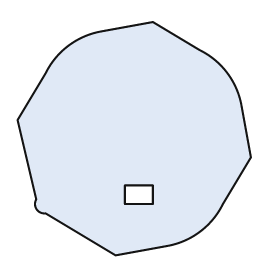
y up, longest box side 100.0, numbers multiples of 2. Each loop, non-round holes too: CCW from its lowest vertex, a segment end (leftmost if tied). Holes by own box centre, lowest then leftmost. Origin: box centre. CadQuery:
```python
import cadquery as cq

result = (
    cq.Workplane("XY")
    .moveTo(-8.0, -50.0)
    .lineTo(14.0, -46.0)
    .threePointArc((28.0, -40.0), (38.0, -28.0))
    .lineTo(50.0, -8.0)
    .lineTo(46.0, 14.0)
    .threePointArc((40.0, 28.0), (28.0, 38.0))
    .lineTo(8.0, 50.0)
    .lineTo(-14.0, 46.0)
    .threePointArc((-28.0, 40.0), (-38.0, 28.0))
    .lineTo(-50.0, 8.0)
    .lineTo(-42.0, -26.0)
    .threePointArc((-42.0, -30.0), (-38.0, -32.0))
    .close()
    .moveTo(-4.0, -28.0)
    .lineTo(8.0, -28.0)
    .lineTo(8.0, -20.0)
    .lineTo(-4.0, -20.0)
    .close()
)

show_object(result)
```